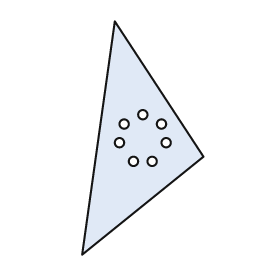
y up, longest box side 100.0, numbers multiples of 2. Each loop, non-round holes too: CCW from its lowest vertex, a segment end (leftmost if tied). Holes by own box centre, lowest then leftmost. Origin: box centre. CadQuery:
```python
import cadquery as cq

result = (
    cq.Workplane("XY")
    .moveTo(-26.0, -50.0)
    .lineTo(26.0, -8.0)
    .lineTo(-12.0, 50.0)
    .close()
    .moveTo(-4.0, -10.0)
    .circle(2.0)
    .moveTo(4.0, -10.0)
    .circle(2.0)
    .moveTo(-10.0, -2.0)
    .circle(2.0)
    .moveTo(10.0, -2.0)
    .circle(2.0)
    .moveTo(-8.0, 6.0)
    .circle(2.0)
    .moveTo(8.0, 6.0)
    .circle(2.0)
    .moveTo(0.0, 10.0)
    .circle(2.0)
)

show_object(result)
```